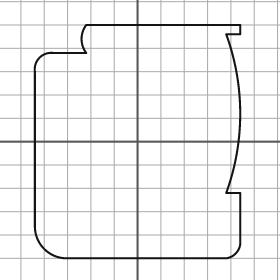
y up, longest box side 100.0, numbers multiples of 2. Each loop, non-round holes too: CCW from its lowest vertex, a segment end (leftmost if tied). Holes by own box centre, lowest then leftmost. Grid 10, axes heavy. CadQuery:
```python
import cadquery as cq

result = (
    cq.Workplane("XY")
    .moveTo(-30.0, -50.0)
    .lineTo(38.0, -50.0)
    .threePointArc((42.0, -48.0), (44.0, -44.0))
    .lineTo(44.0, -22.0)
    .lineTo(38.0, -22.0)
    .threePointArc((44.0, 12.0), (38.0, 46.0))
    .lineTo(44.0, 46.0)
    .lineTo(44.0, 50.0)
    .lineTo(-22.0, 50.0)
    .threePointArc((-24.0, 44.0), (-22.0, 38.0))
    .lineTo(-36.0, 38.0)
    .threePointArc((-42.0, 36.0), (-44.0, 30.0))
    .lineTo(-44.0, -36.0)
    .threePointArc((-40.0, -46.0), (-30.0, -50.0))
    .close()
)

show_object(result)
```